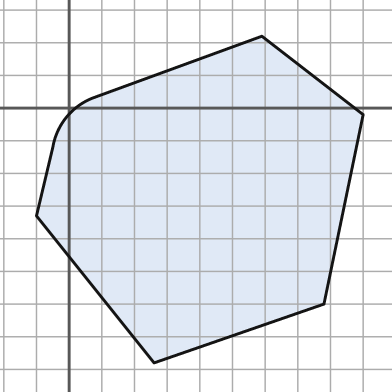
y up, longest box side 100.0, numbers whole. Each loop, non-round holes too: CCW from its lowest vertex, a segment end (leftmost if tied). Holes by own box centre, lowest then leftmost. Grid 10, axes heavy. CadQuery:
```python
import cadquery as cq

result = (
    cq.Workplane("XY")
    .moveTo(26.0, -78.0)
    .lineTo(78.0, -60.0)
    .lineTo(90.0, -2.0)
    .lineTo(59.0, 22.0)
    .lineTo(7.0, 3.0)
    .threePointArc((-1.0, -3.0), (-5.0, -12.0))
    .lineTo(-10.0, -33.0)
    .close()
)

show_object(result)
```